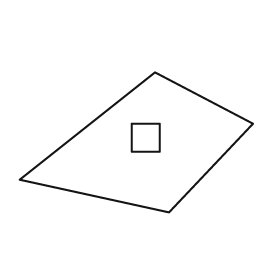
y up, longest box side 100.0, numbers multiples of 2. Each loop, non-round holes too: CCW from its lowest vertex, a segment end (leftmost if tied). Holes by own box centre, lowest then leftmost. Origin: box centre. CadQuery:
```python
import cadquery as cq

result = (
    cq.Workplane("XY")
    .moveTo(14.0, -30.0)
    .lineTo(50.0, 8.0)
    .lineTo(8.0, 30.0)
    .lineTo(-50.0, -16.0)
    .close()
    .moveTo(-2.0, -4.0)
    .lineTo(10.0, -4.0)
    .lineTo(10.0, 8.0)
    .lineTo(-2.0, 8.0)
    .close()
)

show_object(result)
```